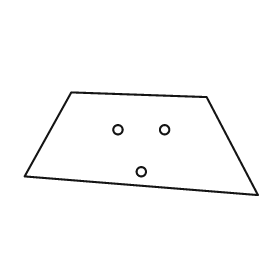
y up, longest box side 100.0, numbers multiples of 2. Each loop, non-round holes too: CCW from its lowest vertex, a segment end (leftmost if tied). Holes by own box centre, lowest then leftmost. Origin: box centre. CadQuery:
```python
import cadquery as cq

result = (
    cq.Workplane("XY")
    .moveTo(50.0, -22.0)
    .lineTo(28.0, 20.0)
    .lineTo(-30.0, 22.0)
    .lineTo(-50.0, -14.0)
    .close()
    .moveTo(0.0, -12.0)
    .circle(2.0)
    .moveTo(-10.0, 6.0)
    .circle(2.0)
    .moveTo(10.0, 6.0)
    .circle(2.0)
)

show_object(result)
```